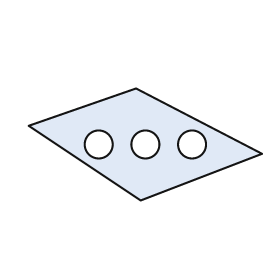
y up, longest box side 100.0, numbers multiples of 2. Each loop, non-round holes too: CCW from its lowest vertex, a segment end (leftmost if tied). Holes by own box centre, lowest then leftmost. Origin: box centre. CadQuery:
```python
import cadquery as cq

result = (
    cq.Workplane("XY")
    .moveTo(-2.0, -24.0)
    .lineTo(50.0, -4.0)
    .lineTo(-4.0, 24.0)
    .lineTo(-50.0, 8.0)
    .close()
    .moveTo(-20.0, 0.0)
    .circle(6.0)
    .moveTo(0.0, 0.0)
    .circle(6.0)
    .moveTo(20.0, 0.0)
    .circle(6.0)
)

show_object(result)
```